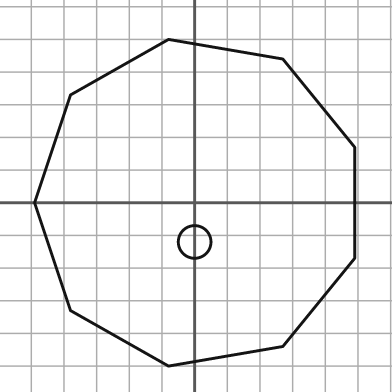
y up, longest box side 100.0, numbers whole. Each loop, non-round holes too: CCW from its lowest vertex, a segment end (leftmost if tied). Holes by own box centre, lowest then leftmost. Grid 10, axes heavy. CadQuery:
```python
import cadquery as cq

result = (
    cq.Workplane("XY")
    .moveTo(-8.0, -50.0)
    .lineTo(27.0, -44.0)
    .lineTo(49.0, -17.0)
    .lineTo(49.0, 17.0)
    .lineTo(27.0, 44.0)
    .lineTo(-8.0, 50.0)
    .lineTo(-38.0, 33.0)
    .lineTo(-49.0, 0.0)
    .lineTo(-38.0, -33.0)
    .close()
    .moveTo(0.0, -12.0)
    .circle(5.0)
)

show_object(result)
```